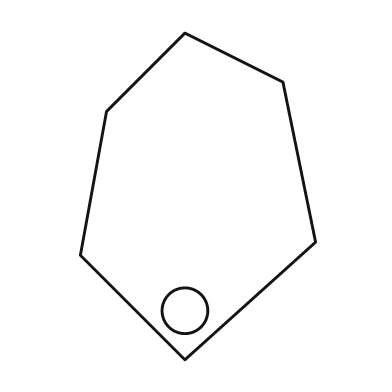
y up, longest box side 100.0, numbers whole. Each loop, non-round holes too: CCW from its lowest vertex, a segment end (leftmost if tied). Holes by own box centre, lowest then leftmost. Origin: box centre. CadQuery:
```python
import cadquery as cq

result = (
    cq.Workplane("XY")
    .moveTo(-4.0, -50.0)
    .lineTo(36.0, -14.0)
    .lineTo(26.0, 35.0)
    .lineTo(-4.0, 50.0)
    .lineTo(-28.0, 26.0)
    .lineTo(-36.0, -18.0)
    .close()
    .moveTo(-4.0, -35.0)
    .circle(7.0)
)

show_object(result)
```